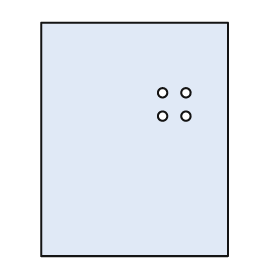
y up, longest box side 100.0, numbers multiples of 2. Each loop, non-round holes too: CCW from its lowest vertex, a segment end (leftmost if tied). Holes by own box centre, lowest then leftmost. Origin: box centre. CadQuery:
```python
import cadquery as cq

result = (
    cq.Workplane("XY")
    .moveTo(-40.0, -50.0)
    .lineTo(40.0, -50.0)
    .lineTo(40.0, 50.0)
    .lineTo(-40.0, 50.0)
    .close()
    .moveTo(12.0, 10.0)
    .circle(2.0)
    .moveTo(22.0, 10.0)
    .circle(2.0)
    .moveTo(12.0, 20.0)
    .circle(2.0)
    .moveTo(22.0, 20.0)
    .circle(2.0)
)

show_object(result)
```